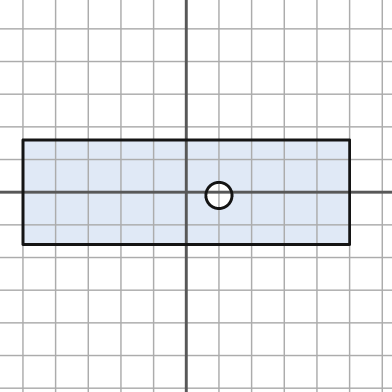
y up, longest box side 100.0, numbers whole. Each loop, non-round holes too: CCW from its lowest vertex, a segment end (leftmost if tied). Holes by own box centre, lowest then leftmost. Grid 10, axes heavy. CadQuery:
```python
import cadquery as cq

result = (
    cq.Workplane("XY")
    .moveTo(-50.0, -16.0)
    .lineTo(50.0, -16.0)
    .lineTo(50.0, 16.0)
    .lineTo(-50.0, 16.0)
    .close()
    .moveTo(10.0, -1.0)
    .circle(4.0)
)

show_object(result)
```